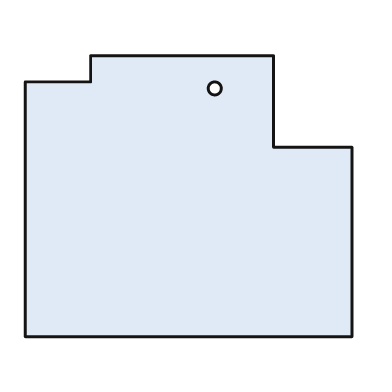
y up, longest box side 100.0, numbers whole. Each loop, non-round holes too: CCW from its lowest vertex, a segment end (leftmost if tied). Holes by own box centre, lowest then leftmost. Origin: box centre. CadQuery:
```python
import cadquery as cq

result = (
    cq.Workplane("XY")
    .moveTo(-50.0, -43.0)
    .lineTo(50.0, -43.0)
    .lineTo(50.0, 15.0)
    .lineTo(26.0, 15.0)
    .lineTo(26.0, 43.0)
    .lineTo(-30.0, 43.0)
    .lineTo(-30.0, 35.0)
    .lineTo(-50.0, 35.0)
    .close()
    .moveTo(8.0, 33.0)
    .circle(2.0)
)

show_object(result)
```